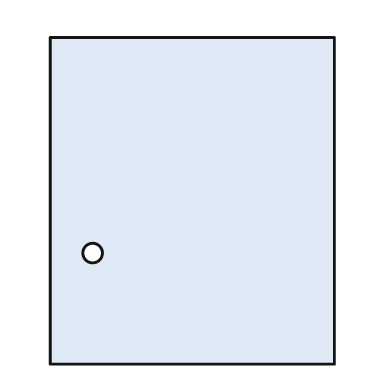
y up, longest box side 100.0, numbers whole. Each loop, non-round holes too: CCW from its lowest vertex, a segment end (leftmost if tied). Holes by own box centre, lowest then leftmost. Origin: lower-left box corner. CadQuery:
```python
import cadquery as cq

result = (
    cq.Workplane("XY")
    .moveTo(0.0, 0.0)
    .lineTo(87.0, 0.0)
    .lineTo(87.0, 100.0)
    .lineTo(0.0, 100.0)
    .close()
    .moveTo(13.0, 34.0)
    .circle(3.0)
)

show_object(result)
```